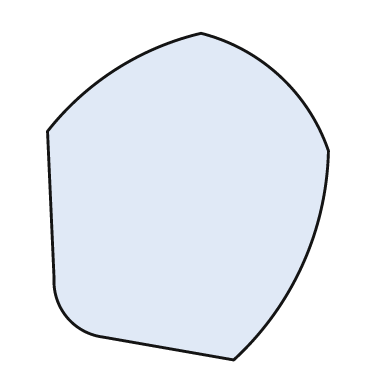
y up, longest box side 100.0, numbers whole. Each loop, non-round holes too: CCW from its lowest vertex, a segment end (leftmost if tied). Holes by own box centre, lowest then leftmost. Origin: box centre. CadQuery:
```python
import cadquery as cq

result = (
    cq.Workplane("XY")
    .moveTo(14.0, -50.0)
    .threePointArc((35.0, -21.0), (43.0, 14.0))
    .threePointArc((28.0, 37.0), (4.0, 50.0))
    .threePointArc((-22.0, 39.0), (-43.0, 20.0))
    .lineTo(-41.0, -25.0)
    .threePointArc((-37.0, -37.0), (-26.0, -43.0))
    .close()
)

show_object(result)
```